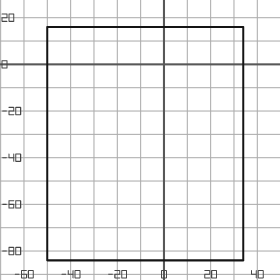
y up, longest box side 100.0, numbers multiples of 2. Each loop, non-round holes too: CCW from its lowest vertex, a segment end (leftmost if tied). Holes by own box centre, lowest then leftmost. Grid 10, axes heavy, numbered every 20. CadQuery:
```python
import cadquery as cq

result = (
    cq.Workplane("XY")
    .moveTo(-50.0, -84.0)
    .lineTo(34.0, -84.0)
    .lineTo(34.0, 16.0)
    .lineTo(-50.0, 16.0)
    .close()
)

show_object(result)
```